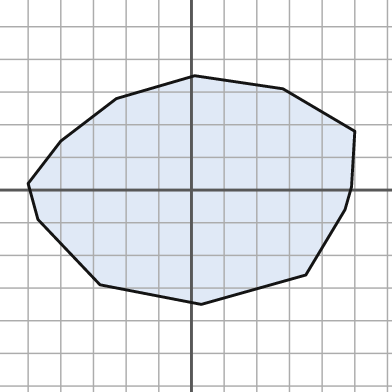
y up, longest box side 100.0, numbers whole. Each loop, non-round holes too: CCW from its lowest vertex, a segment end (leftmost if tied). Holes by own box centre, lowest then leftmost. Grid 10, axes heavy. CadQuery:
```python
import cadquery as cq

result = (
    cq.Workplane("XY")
    .moveTo(3.0, -35.0)
    .lineTo(35.0, -26.0)
    .lineTo(47.0, -6.0)
    .lineTo(49.0, 1.0)
    .lineTo(50.0, 18.0)
    .lineTo(28.0, 31.0)
    .lineTo(1.0, 35.0)
    .lineTo(-23.0, 28.0)
    .lineTo(-40.0, 15.0)
    .lineTo(-50.0, 2.0)
    .lineTo(-47.0, -9.0)
    .lineTo(-28.0, -29.0)
    .close()
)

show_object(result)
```